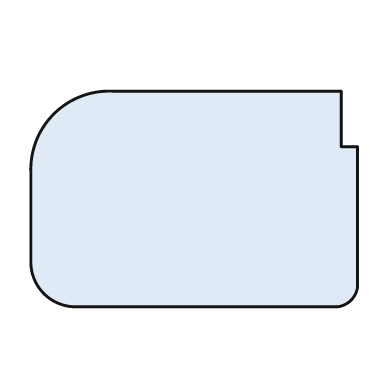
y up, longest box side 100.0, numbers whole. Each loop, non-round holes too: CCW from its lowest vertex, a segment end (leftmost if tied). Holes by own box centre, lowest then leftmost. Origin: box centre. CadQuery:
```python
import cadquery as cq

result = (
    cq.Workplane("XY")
    .moveTo(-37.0, -33.0)
    .lineTo(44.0, -33.0)
    .threePointArc((48.0, -31.0), (50.0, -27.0))
    .lineTo(50.0, 16.0)
    .lineTo(45.0, 16.0)
    .lineTo(45.0, 33.0)
    .lineTo(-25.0, 33.0)
    .threePointArc((-43.0, 26.0), (-50.0, 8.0))
    .lineTo(-50.0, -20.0)
    .threePointArc((-46.0, -29.0), (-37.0, -33.0))
    .close()
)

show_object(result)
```